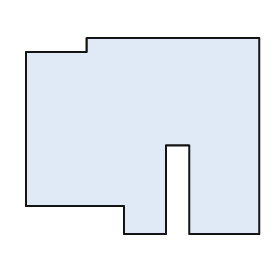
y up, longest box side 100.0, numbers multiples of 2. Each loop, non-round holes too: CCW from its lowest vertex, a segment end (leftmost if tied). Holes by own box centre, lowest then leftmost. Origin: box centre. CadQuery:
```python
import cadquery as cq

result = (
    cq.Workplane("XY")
    .moveTo(-8.0, -42.0)
    .lineTo(10.0, -42.0)
    .lineTo(10.0, -4.0)
    .lineTo(20.0, -4.0)
    .lineTo(20.0, -42.0)
    .lineTo(50.0, -42.0)
    .lineTo(50.0, 42.0)
    .lineTo(-24.0, 42.0)
    .lineTo(-24.0, 36.0)
    .lineTo(-50.0, 36.0)
    .lineTo(-50.0, -30.0)
    .lineTo(-8.0, -30.0)
    .close()
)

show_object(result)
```